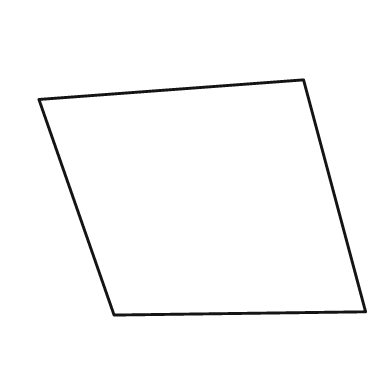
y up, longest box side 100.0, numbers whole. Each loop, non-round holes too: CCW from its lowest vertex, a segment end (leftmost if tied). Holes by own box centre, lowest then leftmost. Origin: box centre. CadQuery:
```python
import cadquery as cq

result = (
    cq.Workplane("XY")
    .moveTo(-27.0, -36.0)
    .lineTo(50.0, -35.0)
    .lineTo(31.0, 36.0)
    .lineTo(-50.0, 30.0)
    .close()
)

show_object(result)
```